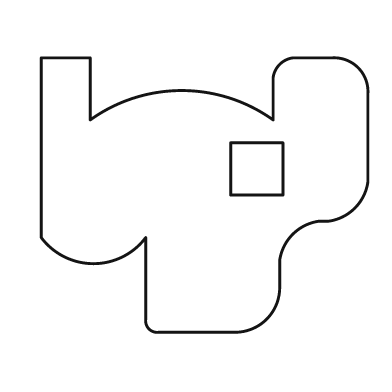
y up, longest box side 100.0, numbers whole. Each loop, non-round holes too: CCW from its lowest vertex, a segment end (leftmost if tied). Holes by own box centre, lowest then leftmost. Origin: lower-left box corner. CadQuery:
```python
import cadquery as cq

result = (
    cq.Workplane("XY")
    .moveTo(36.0, 0.0)
    .lineTo(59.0, 0.0)
    .threePointArc((69.0, 4.0), (73.0, 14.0))
    .lineTo(73.0, 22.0)
    .threePointArc((77.0, 30.0), (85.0, 34.0))
    .lineTo(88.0, 34.0)
    .threePointArc((96.0, 38.0), (100.0, 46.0))
    .lineTo(100.0, 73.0)
    .threePointArc((97.0, 81.0), (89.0, 84.0))
    .lineTo(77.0, 84.0)
    .threePointArc((73.0, 82.0), (71.0, 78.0))
    .lineTo(71.0, 65.0)
    .threePointArc((43.0, 74.0), (15.0, 65.0))
    .lineTo(15.0, 84.0)
    .lineTo(0.0, 84.0)
    .lineTo(0.0, 29.0)
    .threePointArc((16.0, 21.0), (32.0, 29.0))
    .lineTo(32.0, 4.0)
    .threePointArc((33.0, 1.0), (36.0, 0.0))
    .close()
    .moveTo(58.0, 42.0)
    .lineTo(74.0, 42.0)
    .lineTo(74.0, 58.0)
    .lineTo(58.0, 58.0)
    .close()
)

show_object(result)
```